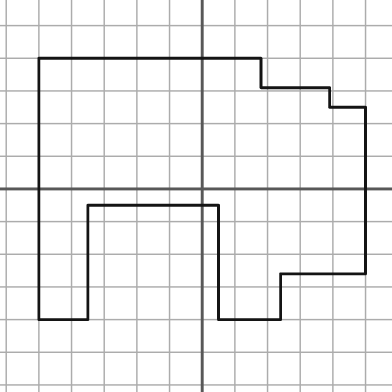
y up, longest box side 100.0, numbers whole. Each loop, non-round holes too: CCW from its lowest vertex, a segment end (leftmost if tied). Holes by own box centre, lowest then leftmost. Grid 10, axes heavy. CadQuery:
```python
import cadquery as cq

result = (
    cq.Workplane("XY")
    .moveTo(-50.0, -40.0)
    .lineTo(-35.0, -40.0)
    .lineTo(-35.0, -5.0)
    .lineTo(5.0, -5.0)
    .lineTo(5.0, -40.0)
    .lineTo(24.0, -40.0)
    .lineTo(24.0, -26.0)
    .lineTo(50.0, -26.0)
    .lineTo(50.0, 25.0)
    .lineTo(39.0, 25.0)
    .lineTo(39.0, 31.0)
    .lineTo(18.0, 31.0)
    .lineTo(18.0, 40.0)
    .lineTo(-50.0, 40.0)
    .close()
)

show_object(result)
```